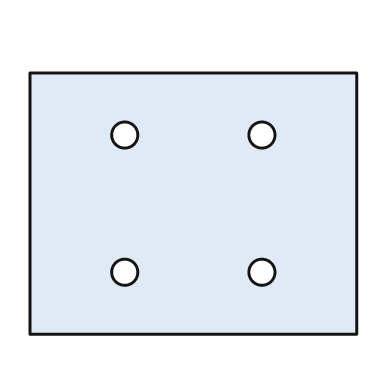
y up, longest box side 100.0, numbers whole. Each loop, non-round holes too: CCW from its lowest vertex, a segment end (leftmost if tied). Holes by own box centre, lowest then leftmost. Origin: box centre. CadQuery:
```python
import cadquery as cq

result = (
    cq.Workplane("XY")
    .moveTo(-50.0, -40.0)
    .lineTo(50.0, -40.0)
    .lineTo(50.0, 40.0)
    .lineTo(-50.0, 40.0)
    .close()
    .moveTo(-21.0, -21.0)
    .circle(4.0)
    .moveTo(21.0, -21.0)
    .circle(4.0)
    .moveTo(-21.0, 21.0)
    .circle(4.0)
    .moveTo(21.0, 21.0)
    .circle(4.0)
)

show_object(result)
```